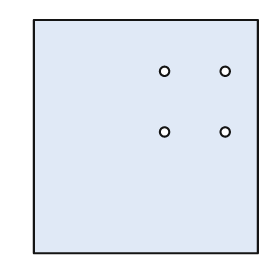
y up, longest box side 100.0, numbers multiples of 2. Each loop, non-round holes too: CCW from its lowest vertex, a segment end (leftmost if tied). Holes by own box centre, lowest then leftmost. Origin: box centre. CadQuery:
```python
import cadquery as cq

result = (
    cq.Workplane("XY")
    .moveTo(-48.0, -50.0)
    .lineTo(48.0, -50.0)
    .lineTo(48.0, 50.0)
    .lineTo(-48.0, 50.0)
    .close()
    .moveTo(8.0, 2.0)
    .circle(2.0)
    .moveTo(34.0, 2.0)
    .circle(2.0)
    .moveTo(8.0, 28.0)
    .circle(2.0)
    .moveTo(34.0, 28.0)
    .circle(2.0)
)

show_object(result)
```